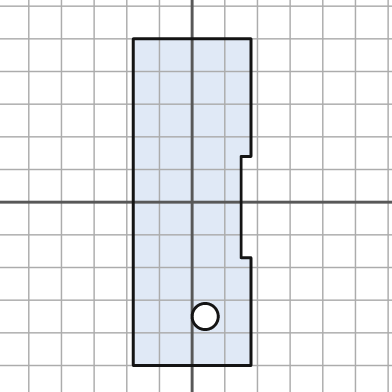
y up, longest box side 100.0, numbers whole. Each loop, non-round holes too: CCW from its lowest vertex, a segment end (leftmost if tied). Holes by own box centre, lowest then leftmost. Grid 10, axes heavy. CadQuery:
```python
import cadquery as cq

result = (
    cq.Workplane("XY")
    .moveTo(-18.0, -50.0)
    .lineTo(18.0, -50.0)
    .lineTo(18.0, -17.0)
    .lineTo(15.0, -17.0)
    .lineTo(15.0, 14.0)
    .lineTo(18.0, 14.0)
    .lineTo(18.0, 50.0)
    .lineTo(-18.0, 50.0)
    .close()
    .moveTo(4.0, -35.0)
    .circle(4.0)
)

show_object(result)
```